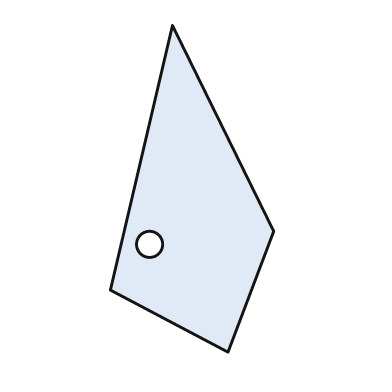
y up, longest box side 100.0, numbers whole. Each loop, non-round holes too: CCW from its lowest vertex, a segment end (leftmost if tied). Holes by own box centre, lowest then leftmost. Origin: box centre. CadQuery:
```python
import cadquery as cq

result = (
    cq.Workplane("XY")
    .moveTo(11.0, -50.0)
    .lineTo(25.0, -13.0)
    .lineTo(-6.0, 50.0)
    .lineTo(-25.0, -31.0)
    .close()
    .moveTo(-13.0, -17.0)
    .circle(4.0)
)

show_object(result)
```